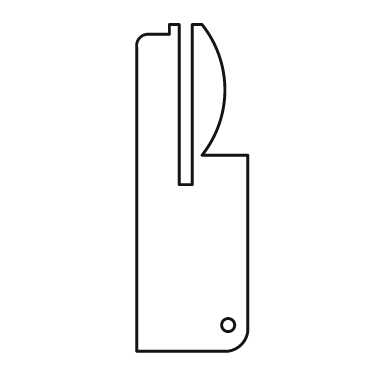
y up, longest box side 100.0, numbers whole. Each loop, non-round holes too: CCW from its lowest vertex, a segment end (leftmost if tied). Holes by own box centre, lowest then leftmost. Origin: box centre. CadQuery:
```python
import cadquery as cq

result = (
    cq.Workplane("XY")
    .moveTo(-17.0, -50.0)
    .lineTo(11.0, -50.0)
    .threePointArc((15.0, -48.0), (17.0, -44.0))
    .lineTo(17.0, 10.0)
    .lineTo(3.0, 10.0)
    .threePointArc((10.0, 30.0), (3.0, 50.0))
    .lineTo(0.0, 50.0)
    .lineTo(0.0, 1.0)
    .lineTo(-4.0, 1.0)
    .lineTo(-4.0, 50.0)
    .lineTo(-7.0, 50.0)
    .lineTo(-7.0, 47.0)
    .lineTo(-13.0, 47.0)
    .threePointArc((-16.0, 46.0), (-17.0, 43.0))
    .close()
    .moveTo(11.0, -42.0)
    .circle(2.0)
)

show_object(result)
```